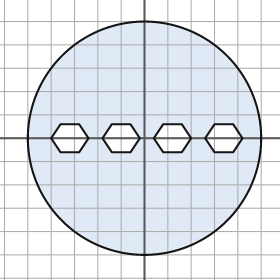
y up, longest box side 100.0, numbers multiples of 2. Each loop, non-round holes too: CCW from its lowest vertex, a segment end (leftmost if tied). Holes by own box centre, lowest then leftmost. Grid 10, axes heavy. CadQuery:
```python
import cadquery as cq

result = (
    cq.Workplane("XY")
    .moveTo(0.0, 0.0)
    .circle(50.0)
    .moveTo(-36.0, -6.0)
    .lineTo(-28.0, -6.0)
    .lineTo(-24.0, 0.0)
    .lineTo(-28.0, 6.0)
    .lineTo(-36.0, 6.0)
    .lineTo(-40.0, 0.0)
    .close()
    .moveTo(-14.0, -6.0)
    .lineTo(-6.0, -6.0)
    .lineTo(-2.0, 0.0)
    .lineTo(-6.0, 6.0)
    .lineTo(-14.0, 6.0)
    .lineTo(-18.0, 0.0)
    .close()
    .moveTo(8.0, -6.0)
    .lineTo(16.0, -6.0)
    .lineTo(20.0, 0.0)
    .lineTo(16.0, 6.0)
    .lineTo(8.0, 6.0)
    .lineTo(4.0, 0.0)
    .close()
    .moveTo(30.0, -6.0)
    .lineTo(38.0, -6.0)
    .lineTo(42.0, 0.0)
    .lineTo(38.0, 6.0)
    .lineTo(30.0, 6.0)
    .lineTo(26.0, 0.0)
    .close()
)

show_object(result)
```